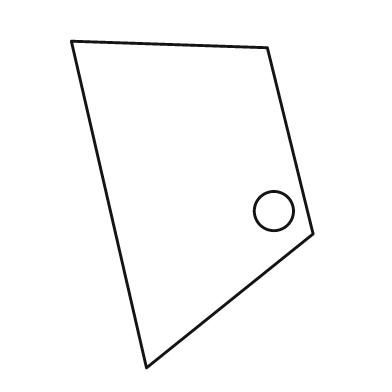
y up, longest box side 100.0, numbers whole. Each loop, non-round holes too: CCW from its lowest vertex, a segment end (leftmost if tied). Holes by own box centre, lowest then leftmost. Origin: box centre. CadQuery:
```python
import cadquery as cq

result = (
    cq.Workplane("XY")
    .moveTo(-14.0, -50.0)
    .lineTo(37.0, -9.0)
    .lineTo(23.0, 48.0)
    .lineTo(-37.0, 50.0)
    .close()
    .moveTo(25.0, -2.0)
    .circle(6.0)
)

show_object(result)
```